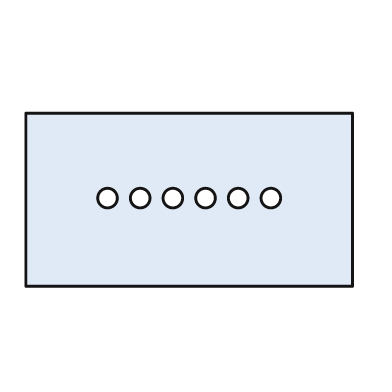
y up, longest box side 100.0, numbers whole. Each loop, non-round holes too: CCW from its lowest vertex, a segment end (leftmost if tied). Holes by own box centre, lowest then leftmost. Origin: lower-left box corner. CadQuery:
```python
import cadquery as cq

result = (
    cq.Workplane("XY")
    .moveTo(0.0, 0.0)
    .lineTo(100.0, 0.0)
    .lineTo(100.0, 53.0)
    .lineTo(0.0, 53.0)
    .close()
    .moveTo(25.0, 27.0)
    .circle(3.0)
    .moveTo(35.0, 27.0)
    .circle(3.0)
    .moveTo(45.0, 27.0)
    .circle(3.0)
    .moveTo(55.0, 27.0)
    .circle(3.0)
    .moveTo(65.0, 27.0)
    .circle(3.0)
    .moveTo(75.0, 27.0)
    .circle(3.0)
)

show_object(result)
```